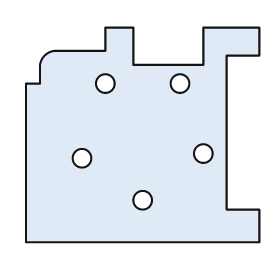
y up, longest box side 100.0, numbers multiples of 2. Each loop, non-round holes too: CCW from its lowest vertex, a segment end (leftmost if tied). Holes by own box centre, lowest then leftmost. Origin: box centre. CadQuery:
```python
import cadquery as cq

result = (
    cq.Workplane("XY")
    .moveTo(-50.0, -46.0)
    .lineTo(50.0, -46.0)
    .lineTo(50.0, -32.0)
    .lineTo(36.0, -32.0)
    .lineTo(36.0, 34.0)
    .lineTo(50.0, 34.0)
    .lineTo(50.0, 46.0)
    .lineTo(26.0, 46.0)
    .lineTo(26.0, 30.0)
    .lineTo(-4.0, 30.0)
    .lineTo(-4.0, 46.0)
    .lineTo(-16.0, 46.0)
    .lineTo(-16.0, 36.0)
    .lineTo(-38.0, 36.0)
    .threePointArc((-42.0, 34.0), (-44.0, 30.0))
    .lineTo(-44.0, 22.0)
    .lineTo(-50.0, 22.0)
    .close()
    .moveTo(0.0, -28.0)
    .circle(4.0)
    .moveTo(-26.0, -10.0)
    .circle(4.0)
    .moveTo(26.0, -8.0)
    .circle(4.0)
    .moveTo(-16.0, 22.0)
    .circle(4.0)
    .moveTo(16.0, 22.0)
    .circle(4.0)
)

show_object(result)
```